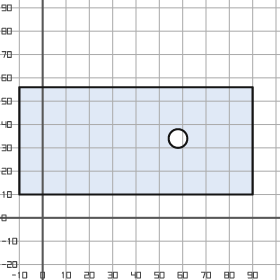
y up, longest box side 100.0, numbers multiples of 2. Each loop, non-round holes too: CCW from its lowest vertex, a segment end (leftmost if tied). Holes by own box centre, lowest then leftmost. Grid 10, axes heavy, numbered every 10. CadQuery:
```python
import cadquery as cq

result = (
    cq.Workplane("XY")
    .moveTo(-10.0, 10.0)
    .lineTo(90.0, 10.0)
    .lineTo(90.0, 56.0)
    .lineTo(-10.0, 56.0)
    .close()
    .moveTo(58.0, 34.0)
    .circle(4.0)
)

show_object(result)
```